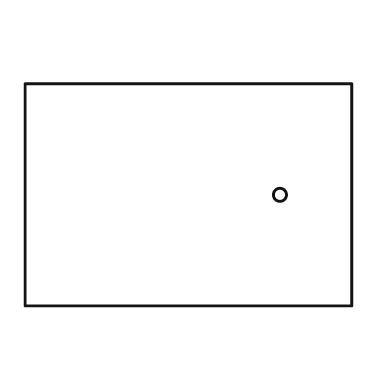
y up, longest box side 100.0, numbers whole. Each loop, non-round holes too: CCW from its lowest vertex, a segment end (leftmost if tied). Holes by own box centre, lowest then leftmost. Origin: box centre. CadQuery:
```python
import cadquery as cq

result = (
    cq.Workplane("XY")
    .moveTo(-50.0, -34.0)
    .lineTo(50.0, -34.0)
    .lineTo(50.0, 34.0)
    .lineTo(-50.0, 34.0)
    .close()
    .moveTo(28.0, 0.0)
    .circle(2.0)
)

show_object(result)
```